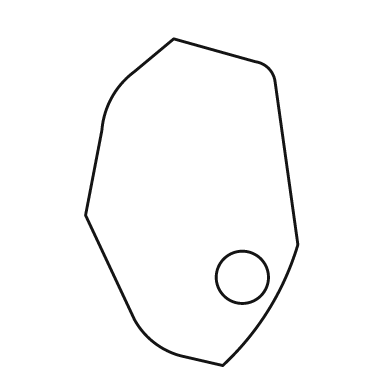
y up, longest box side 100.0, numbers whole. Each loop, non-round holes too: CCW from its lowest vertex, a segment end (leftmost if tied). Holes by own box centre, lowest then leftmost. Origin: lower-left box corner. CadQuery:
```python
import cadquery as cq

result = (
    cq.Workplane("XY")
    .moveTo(42.0, 0.0)
    .threePointArc((56.0, 17.0), (65.0, 37.0))
    .lineTo(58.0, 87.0)
    .threePointArc((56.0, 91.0), (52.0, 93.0))
    .lineTo(27.0, 100.0)
    .lineTo(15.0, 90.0)
    .threePointArc((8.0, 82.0), (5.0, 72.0))
    .lineTo(0.0, 46.0)
    .lineTo(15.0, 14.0)
    .threePointArc((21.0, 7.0), (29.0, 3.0))
    .close()
    .moveTo(48.0, 27.0)
    .circle(8.0)
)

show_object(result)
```